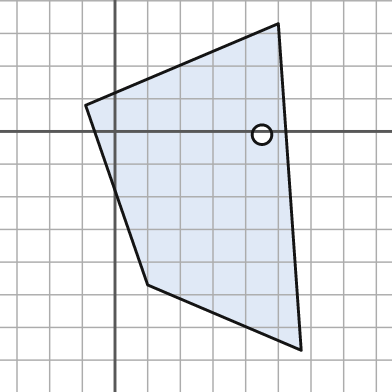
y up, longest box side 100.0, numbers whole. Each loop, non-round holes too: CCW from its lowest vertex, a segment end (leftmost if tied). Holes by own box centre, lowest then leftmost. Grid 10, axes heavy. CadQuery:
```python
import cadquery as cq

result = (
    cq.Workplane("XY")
    .moveTo(57.0, -67.0)
    .lineTo(50.0, 33.0)
    .lineTo(-9.0, 8.0)
    .lineTo(10.0, -47.0)
    .close()
    .moveTo(45.0, -1.0)
    .circle(3.0)
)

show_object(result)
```